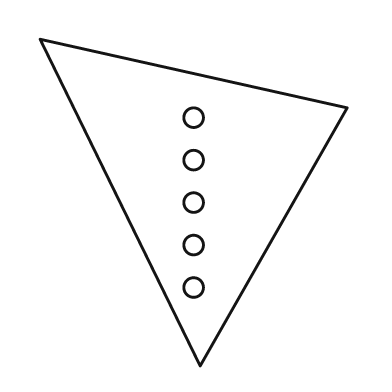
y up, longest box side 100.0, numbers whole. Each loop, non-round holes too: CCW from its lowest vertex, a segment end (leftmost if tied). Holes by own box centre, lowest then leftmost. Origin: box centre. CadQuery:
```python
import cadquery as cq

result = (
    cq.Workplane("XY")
    .moveTo(2.0, -50.0)
    .lineTo(47.0, 29.0)
    .lineTo(-47.0, 50.0)
    .close()
    .moveTo(0.0, -26.0)
    .circle(3.0)
    .moveTo(0.0, -13.0)
    .circle(3.0)
    .moveTo(0.0, 0.0)
    .circle(3.0)
    .moveTo(0.0, 13.0)
    .circle(3.0)
    .moveTo(0.0, 26.0)
    .circle(3.0)
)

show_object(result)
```